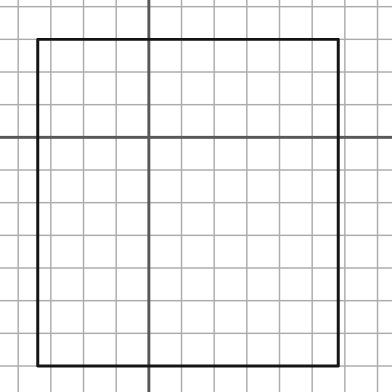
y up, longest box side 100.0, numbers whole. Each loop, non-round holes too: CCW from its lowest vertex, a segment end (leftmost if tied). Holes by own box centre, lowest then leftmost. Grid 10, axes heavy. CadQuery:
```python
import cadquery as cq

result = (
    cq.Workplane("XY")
    .moveTo(-34.0, -70.0)
    .lineTo(58.0, -70.0)
    .lineTo(58.0, 30.0)
    .lineTo(-34.0, 30.0)
    .close()
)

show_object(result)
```